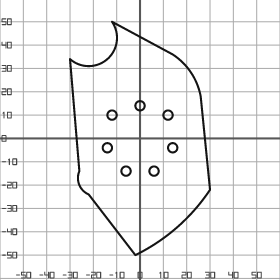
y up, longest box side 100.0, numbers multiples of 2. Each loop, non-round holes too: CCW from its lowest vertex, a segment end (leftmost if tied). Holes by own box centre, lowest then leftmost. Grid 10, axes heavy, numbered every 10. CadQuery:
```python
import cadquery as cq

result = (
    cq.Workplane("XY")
    .moveTo(-2.0, -50.0)
    .threePointArc((16.0, -38.0), (30.0, -22.0))
    .lineTo(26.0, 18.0)
    .threePointArc((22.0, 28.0), (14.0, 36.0))
    .lineTo(-12.0, 50.0)
    .threePointArc((-14.0, 34.0), (-30.0, 34.0))
    .lineTo(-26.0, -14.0)
    .threePointArc((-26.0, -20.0), (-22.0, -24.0))
    .close()
    .moveTo(-6.0, -14.0)
    .circle(2.0)
    .moveTo(6.0, -14.0)
    .circle(2.0)
    .moveTo(-14.0, -4.0)
    .circle(2.0)
    .moveTo(14.0, -4.0)
    .circle(2.0)
    .moveTo(-12.0, 10.0)
    .circle(2.0)
    .moveTo(12.0, 10.0)
    .circle(2.0)
    .moveTo(0.0, 14.0)
    .circle(2.0)
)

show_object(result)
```